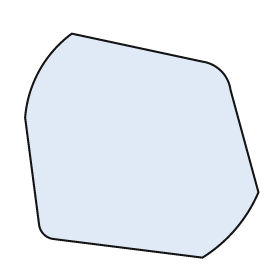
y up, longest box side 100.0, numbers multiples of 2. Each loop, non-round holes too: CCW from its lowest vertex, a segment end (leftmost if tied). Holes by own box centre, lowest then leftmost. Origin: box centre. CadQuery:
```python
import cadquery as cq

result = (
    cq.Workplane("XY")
    .moveTo(26.0, -48.0)
    .threePointArc((40.0, -36.0), (50.0, -20.0))
    .lineTo(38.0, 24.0)
    .threePointArc((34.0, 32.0), (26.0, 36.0))
    .lineTo(-30.0, 48.0)
    .threePointArc((-44.0, 32.0), (-50.0, 12.0))
    .lineTo(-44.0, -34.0)
    .threePointArc((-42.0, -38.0), (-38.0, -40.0))
    .close()
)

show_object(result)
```